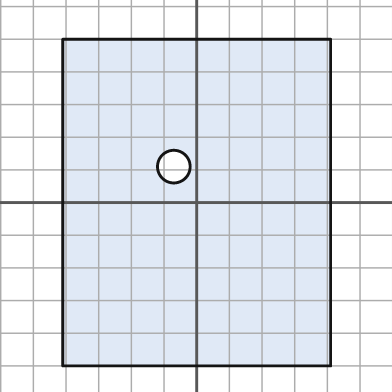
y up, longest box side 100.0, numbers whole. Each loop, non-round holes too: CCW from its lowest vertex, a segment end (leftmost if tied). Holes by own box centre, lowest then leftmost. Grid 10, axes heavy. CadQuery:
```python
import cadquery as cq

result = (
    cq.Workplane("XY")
    .moveTo(-41.0, -50.0)
    .lineTo(41.0, -50.0)
    .lineTo(41.0, 50.0)
    .lineTo(-41.0, 50.0)
    .close()
    .moveTo(-7.0, 11.0)
    .circle(5.0)
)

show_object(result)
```